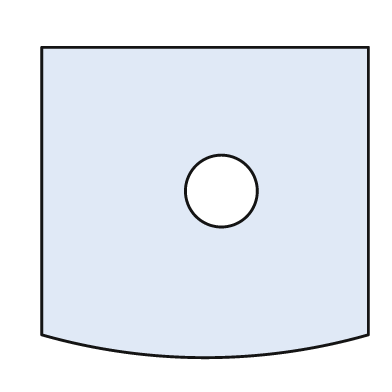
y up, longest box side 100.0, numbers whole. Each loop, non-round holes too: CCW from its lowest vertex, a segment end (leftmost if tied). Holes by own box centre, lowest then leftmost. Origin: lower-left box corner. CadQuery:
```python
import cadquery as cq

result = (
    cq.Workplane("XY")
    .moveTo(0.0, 7.0)
    .threePointArc((50.0, 0.0), (100.0, 7.0))
    .lineTo(100.0, 95.0)
    .lineTo(0.0, 95.0)
    .close()
    .moveTo(55.0, 51.0)
    .circle(11.0)
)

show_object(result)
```